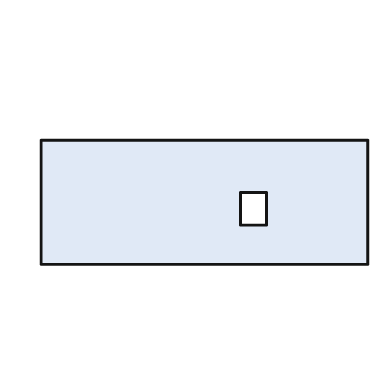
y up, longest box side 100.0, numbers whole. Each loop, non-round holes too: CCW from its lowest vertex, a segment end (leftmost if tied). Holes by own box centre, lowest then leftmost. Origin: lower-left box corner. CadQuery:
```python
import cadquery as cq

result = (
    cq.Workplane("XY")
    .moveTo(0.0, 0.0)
    .lineTo(100.0, 0.0)
    .lineTo(100.0, 38.0)
    .lineTo(0.0, 38.0)
    .close()
    .moveTo(61.0, 12.0)
    .lineTo(69.0, 12.0)
    .lineTo(69.0, 22.0)
    .lineTo(61.0, 22.0)
    .close()
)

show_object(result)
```